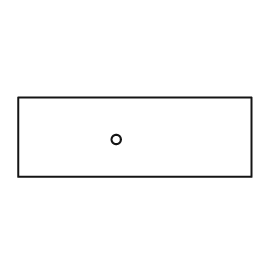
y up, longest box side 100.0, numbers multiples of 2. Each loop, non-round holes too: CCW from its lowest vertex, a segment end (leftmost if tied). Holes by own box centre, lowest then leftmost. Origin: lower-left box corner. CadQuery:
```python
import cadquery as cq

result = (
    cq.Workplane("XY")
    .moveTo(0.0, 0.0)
    .lineTo(100.0, 0.0)
    .lineTo(100.0, 34.0)
    .lineTo(0.0, 34.0)
    .close()
    .moveTo(42.0, 16.0)
    .circle(2.0)
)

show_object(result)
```